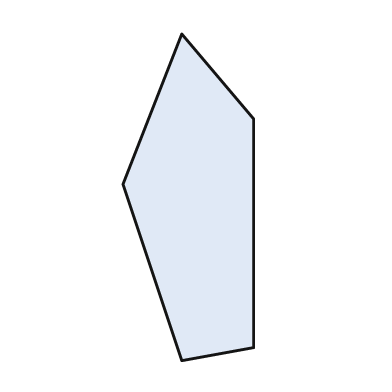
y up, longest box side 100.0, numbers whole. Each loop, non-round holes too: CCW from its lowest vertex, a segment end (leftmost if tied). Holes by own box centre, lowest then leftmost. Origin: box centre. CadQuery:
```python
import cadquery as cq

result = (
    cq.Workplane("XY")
    .moveTo(-2.0, -50.0)
    .lineTo(20.0, -46.0)
    .lineTo(20.0, 24.0)
    .lineTo(-2.0, 50.0)
    .lineTo(-20.0, 4.0)
    .close()
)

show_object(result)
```